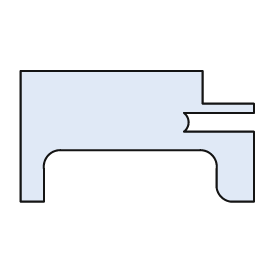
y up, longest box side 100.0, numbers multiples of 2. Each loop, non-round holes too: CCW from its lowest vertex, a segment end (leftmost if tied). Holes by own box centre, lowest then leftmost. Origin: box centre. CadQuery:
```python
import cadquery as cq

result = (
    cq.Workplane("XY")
    .moveTo(-50.0, -28.0)
    .lineTo(-40.0, -28.0)
    .lineTo(-40.0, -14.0)
    .threePointArc((-38.0, -8.0), (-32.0, -6.0))
    .lineTo(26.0, -6.0)
    .threePointArc((32.0, -8.0), (34.0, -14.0))
    .lineTo(34.0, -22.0)
    .threePointArc((36.0, -26.0), (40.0, -28.0))
    .lineTo(50.0, -28.0)
    .lineTo(50.0, 2.0)
    .lineTo(20.0, 2.0)
    .threePointArc((22.0, 6.0), (20.0, 10.0))
    .lineTo(50.0, 10.0)
    .lineTo(50.0, 14.0)
    .lineTo(28.0, 14.0)
    .lineTo(28.0, 28.0)
    .lineTo(-50.0, 28.0)
    .close()
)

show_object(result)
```